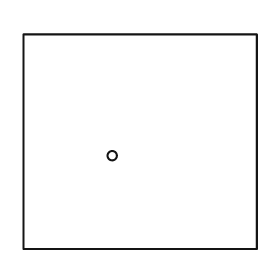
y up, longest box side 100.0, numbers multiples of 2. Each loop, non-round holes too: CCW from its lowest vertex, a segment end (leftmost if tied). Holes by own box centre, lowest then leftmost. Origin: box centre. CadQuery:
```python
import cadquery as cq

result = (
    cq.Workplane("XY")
    .moveTo(-50.0, -46.0)
    .lineTo(50.0, -46.0)
    .lineTo(50.0, 46.0)
    .lineTo(-50.0, 46.0)
    .close()
    .moveTo(-12.0, -6.0)
    .circle(2.0)
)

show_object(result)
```